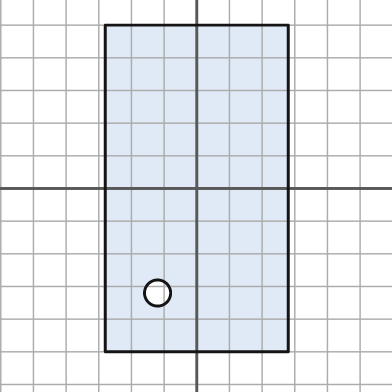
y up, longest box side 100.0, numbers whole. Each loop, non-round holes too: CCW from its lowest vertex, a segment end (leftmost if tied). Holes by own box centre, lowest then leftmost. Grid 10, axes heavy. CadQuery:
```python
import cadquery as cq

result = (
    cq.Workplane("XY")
    .moveTo(-28.0, -50.0)
    .lineTo(28.0, -50.0)
    .lineTo(28.0, 50.0)
    .lineTo(-28.0, 50.0)
    .close()
    .moveTo(-12.0, -32.0)
    .circle(4.0)
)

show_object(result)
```